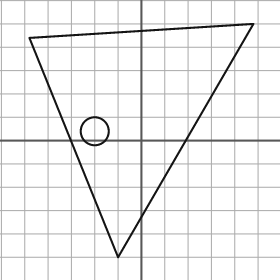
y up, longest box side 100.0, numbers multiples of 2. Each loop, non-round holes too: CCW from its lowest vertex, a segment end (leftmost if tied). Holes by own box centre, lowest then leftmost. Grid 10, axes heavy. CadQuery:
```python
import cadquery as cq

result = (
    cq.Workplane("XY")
    .moveTo(-10.0, -50.0)
    .lineTo(48.0, 50.0)
    .lineTo(-48.0, 44.0)
    .close()
    .moveTo(-20.0, 4.0)
    .circle(6.0)
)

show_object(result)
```